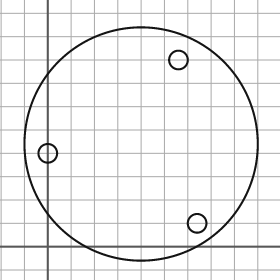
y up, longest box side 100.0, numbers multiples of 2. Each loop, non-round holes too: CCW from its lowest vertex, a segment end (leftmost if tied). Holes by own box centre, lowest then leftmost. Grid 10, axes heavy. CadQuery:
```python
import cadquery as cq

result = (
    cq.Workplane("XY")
    .moveTo(40.0, 44.0)
    .circle(50.0)
    .moveTo(64.0, 10.0)
    .circle(4.0)
    .moveTo(0.0, 40.0)
    .circle(4.0)
    .moveTo(56.0, 80.0)
    .circle(4.0)
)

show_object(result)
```